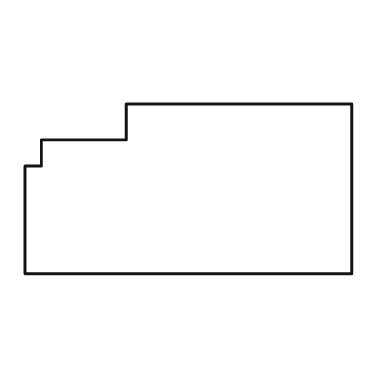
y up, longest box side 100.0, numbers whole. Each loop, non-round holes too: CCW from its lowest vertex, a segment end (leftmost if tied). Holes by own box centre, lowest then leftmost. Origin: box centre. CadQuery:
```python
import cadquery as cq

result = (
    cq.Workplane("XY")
    .moveTo(-50.0, -26.0)
    .lineTo(50.0, -26.0)
    .lineTo(50.0, 26.0)
    .lineTo(-19.0, 26.0)
    .lineTo(-19.0, 15.0)
    .lineTo(-45.0, 15.0)
    .lineTo(-45.0, 7.0)
    .lineTo(-50.0, 7.0)
    .close()
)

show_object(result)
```